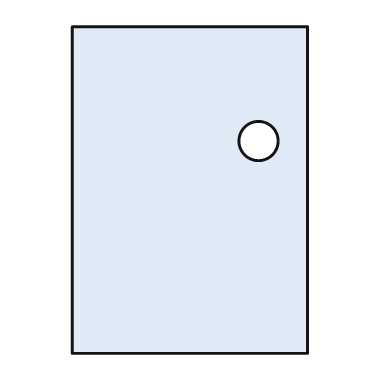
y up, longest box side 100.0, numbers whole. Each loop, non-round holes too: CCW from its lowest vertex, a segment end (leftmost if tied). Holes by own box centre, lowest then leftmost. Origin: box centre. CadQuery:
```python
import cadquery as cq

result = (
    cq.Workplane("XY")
    .moveTo(-36.0, -50.0)
    .lineTo(36.0, -50.0)
    .lineTo(36.0, 50.0)
    .lineTo(-36.0, 50.0)
    .close()
    .moveTo(21.0, 15.0)
    .circle(6.0)
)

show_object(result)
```